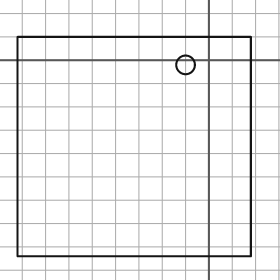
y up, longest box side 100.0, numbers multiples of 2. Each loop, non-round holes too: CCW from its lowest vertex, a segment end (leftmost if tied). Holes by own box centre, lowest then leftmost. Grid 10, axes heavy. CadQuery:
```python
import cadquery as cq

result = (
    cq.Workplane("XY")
    .moveTo(-82.0, -84.0)
    .lineTo(18.0, -84.0)
    .lineTo(18.0, 10.0)
    .lineTo(-82.0, 10.0)
    .close()
    .moveTo(-10.0, -2.0)
    .circle(4.0)
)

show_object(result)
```